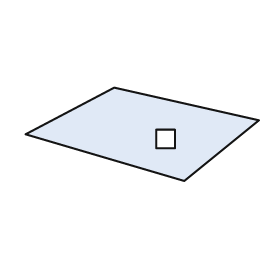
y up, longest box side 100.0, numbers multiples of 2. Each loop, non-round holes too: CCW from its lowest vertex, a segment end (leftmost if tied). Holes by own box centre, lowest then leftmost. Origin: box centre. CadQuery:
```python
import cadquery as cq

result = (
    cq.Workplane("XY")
    .moveTo(18.0, -20.0)
    .lineTo(50.0, 6.0)
    .lineTo(-12.0, 20.0)
    .lineTo(-50.0, 0.0)
    .close()
    .moveTo(6.0, -6.0)
    .lineTo(14.0, -6.0)
    .lineTo(14.0, 2.0)
    .lineTo(6.0, 2.0)
    .close()
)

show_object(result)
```